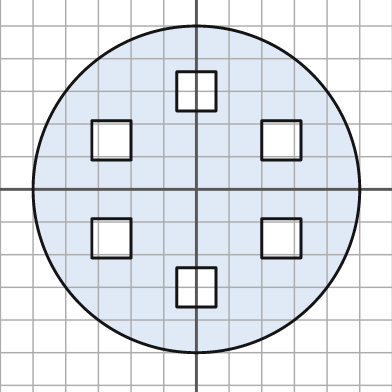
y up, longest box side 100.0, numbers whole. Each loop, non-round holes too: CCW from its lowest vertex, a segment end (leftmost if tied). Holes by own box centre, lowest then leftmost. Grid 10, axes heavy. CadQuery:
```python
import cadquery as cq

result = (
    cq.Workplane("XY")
    .moveTo(0.0, 0.0)
    .circle(50.0)
    .moveTo(-6.0, -36.0)
    .lineTo(6.0, -36.0)
    .lineTo(6.0, -24.0)
    .lineTo(-6.0, -24.0)
    .close()
    .moveTo(-32.0, -21.0)
    .lineTo(-20.0, -21.0)
    .lineTo(-20.0, -9.0)
    .lineTo(-32.0, -9.0)
    .close()
    .moveTo(20.0, -21.0)
    .lineTo(32.0, -21.0)
    .lineTo(32.0, -9.0)
    .lineTo(20.0, -9.0)
    .close()
    .moveTo(-32.0, 9.0)
    .lineTo(-20.0, 9.0)
    .lineTo(-20.0, 21.0)
    .lineTo(-32.0, 21.0)
    .close()
    .moveTo(20.0, 9.0)
    .lineTo(32.0, 9.0)
    .lineTo(32.0, 21.0)
    .lineTo(20.0, 21.0)
    .close()
    .moveTo(-6.0, 24.0)
    .lineTo(6.0, 24.0)
    .lineTo(6.0, 36.0)
    .lineTo(-6.0, 36.0)
    .close()
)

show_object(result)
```